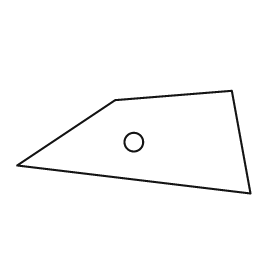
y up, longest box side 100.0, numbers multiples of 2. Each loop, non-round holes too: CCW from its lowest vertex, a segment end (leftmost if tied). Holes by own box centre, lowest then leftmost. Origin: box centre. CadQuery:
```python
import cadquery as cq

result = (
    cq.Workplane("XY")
    .moveTo(50.0, -22.0)
    .lineTo(42.0, 22.0)
    .lineTo(-8.0, 18.0)
    .lineTo(-50.0, -10.0)
    .close()
    .moveTo(0.0, 0.0)
    .circle(4.0)
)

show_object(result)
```